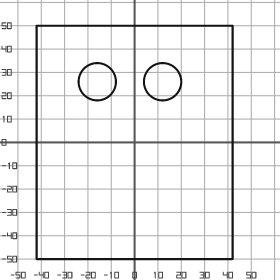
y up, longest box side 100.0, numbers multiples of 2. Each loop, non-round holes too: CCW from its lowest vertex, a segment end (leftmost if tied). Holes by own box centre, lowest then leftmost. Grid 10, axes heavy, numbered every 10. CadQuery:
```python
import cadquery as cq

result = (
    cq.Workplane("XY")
    .moveTo(-42.0, -50.0)
    .lineTo(42.0, -50.0)
    .lineTo(42.0, 50.0)
    .lineTo(-42.0, 50.0)
    .close()
    .moveTo(-16.0, 26.0)
    .circle(8.0)
    .moveTo(12.0, 26.0)
    .circle(8.0)
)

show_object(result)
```